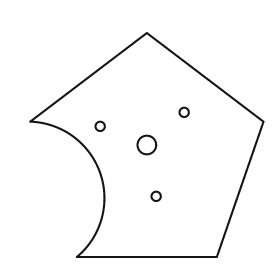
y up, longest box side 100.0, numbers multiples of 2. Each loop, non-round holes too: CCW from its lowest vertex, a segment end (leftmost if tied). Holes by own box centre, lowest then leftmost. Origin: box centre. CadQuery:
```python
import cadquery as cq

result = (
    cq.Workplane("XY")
    .moveTo(-30.0, -48.0)
    .lineTo(30.0, -48.0)
    .lineTo(50.0, 10.0)
    .lineTo(0.0, 48.0)
    .lineTo(-50.0, 10.0)
    .threePointArc((-20.0, -12.0), (-30.0, -48.0))
    .close()
    .moveTo(4.0, -22.0)
    .circle(2.0)
    .moveTo(0.0, 0.0)
    .circle(4.0)
    .moveTo(-20.0, 8.0)
    .circle(2.0)
    .moveTo(16.0, 14.0)
    .circle(2.0)
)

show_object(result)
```